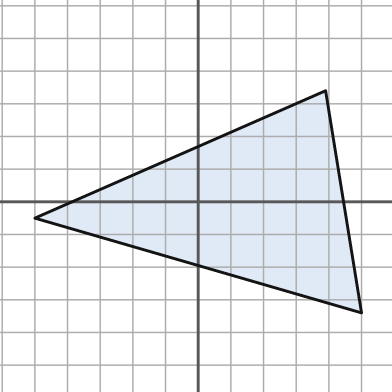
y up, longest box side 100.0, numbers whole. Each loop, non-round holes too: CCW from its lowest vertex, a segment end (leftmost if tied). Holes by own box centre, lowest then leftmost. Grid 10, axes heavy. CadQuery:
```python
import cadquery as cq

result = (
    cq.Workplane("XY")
    .moveTo(50.0, -34.0)
    .lineTo(39.0, 34.0)
    .lineTo(-50.0, -5.0)
    .close()
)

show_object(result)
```